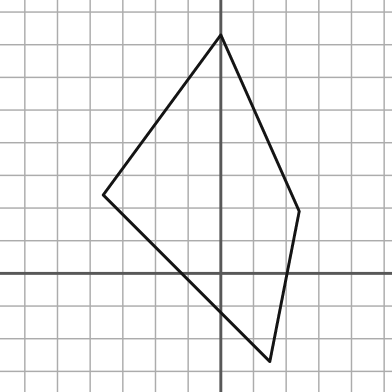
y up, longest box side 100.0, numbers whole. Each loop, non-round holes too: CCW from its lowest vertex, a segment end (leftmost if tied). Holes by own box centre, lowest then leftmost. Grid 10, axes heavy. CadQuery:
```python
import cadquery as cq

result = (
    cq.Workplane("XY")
    .moveTo(15.0, -27.0)
    .lineTo(24.0, 19.0)
    .lineTo(0.0, 73.0)
    .lineTo(-36.0, 24.0)
    .close()
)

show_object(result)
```